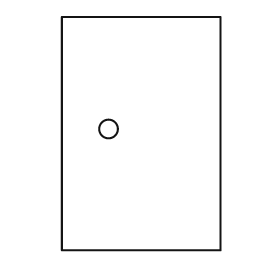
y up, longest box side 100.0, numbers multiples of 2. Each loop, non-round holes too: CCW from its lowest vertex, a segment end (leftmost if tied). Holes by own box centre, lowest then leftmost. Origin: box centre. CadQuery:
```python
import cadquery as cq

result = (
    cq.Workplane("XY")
    .moveTo(-34.0, -50.0)
    .lineTo(34.0, -50.0)
    .lineTo(34.0, 50.0)
    .lineTo(-34.0, 50.0)
    .close()
    .moveTo(-14.0, 2.0)
    .circle(4.0)
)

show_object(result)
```